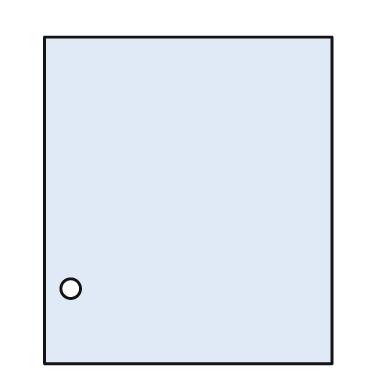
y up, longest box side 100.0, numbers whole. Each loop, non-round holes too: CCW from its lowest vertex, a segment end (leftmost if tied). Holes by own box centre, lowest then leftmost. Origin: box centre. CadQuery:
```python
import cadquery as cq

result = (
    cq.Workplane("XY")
    .moveTo(-44.0, -50.0)
    .lineTo(44.0, -50.0)
    .lineTo(44.0, 50.0)
    .lineTo(-44.0, 50.0)
    .close()
    .moveTo(-36.0, -27.0)
    .circle(3.0)
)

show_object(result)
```